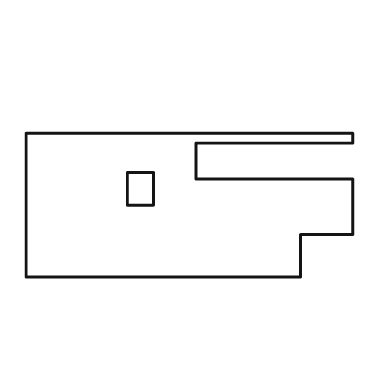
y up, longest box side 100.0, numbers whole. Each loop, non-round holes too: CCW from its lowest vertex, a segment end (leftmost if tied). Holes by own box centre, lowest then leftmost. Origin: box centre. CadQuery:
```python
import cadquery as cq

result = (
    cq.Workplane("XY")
    .moveTo(-50.0, -22.0)
    .lineTo(34.0, -22.0)
    .lineTo(34.0, -9.0)
    .lineTo(50.0, -9.0)
    .lineTo(50.0, 8.0)
    .lineTo(2.0, 8.0)
    .lineTo(2.0, 19.0)
    .lineTo(50.0, 19.0)
    .lineTo(50.0, 22.0)
    .lineTo(-50.0, 22.0)
    .close()
    .moveTo(-19.0, 0.0)
    .lineTo(-11.0, 0.0)
    .lineTo(-11.0, 10.0)
    .lineTo(-19.0, 10.0)
    .close()
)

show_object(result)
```